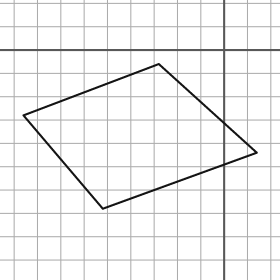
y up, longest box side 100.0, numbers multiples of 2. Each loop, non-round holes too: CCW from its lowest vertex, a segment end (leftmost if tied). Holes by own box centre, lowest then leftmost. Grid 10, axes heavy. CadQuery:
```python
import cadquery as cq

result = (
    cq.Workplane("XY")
    .moveTo(-52.0, -68.0)
    .lineTo(14.0, -44.0)
    .lineTo(-28.0, -6.0)
    .lineTo(-86.0, -28.0)
    .close()
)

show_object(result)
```